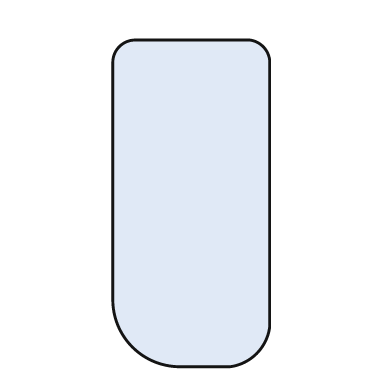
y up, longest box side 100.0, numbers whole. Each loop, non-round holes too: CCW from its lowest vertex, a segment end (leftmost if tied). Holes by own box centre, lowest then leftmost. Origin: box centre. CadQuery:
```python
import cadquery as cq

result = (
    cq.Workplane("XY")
    .moveTo(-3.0, -50.0)
    .lineTo(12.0, -50.0)
    .threePointArc((20.0, -46.0), (24.0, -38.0))
    .lineTo(24.0, 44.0)
    .threePointArc((22.0, 48.0), (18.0, 50.0))
    .lineTo(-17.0, 50.0)
    .threePointArc((-22.0, 48.0), (-24.0, 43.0))
    .lineTo(-24.0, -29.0)
    .threePointArc((-18.0, -44.0), (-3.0, -50.0))
    .close()
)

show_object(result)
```